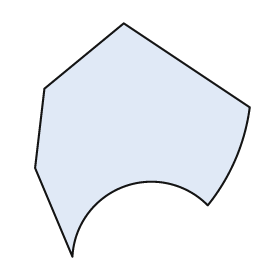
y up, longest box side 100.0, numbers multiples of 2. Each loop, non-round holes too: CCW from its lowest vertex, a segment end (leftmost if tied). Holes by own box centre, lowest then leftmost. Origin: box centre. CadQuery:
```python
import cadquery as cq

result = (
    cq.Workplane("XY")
    .moveTo(-30.0, -50.0)
    .threePointArc((-8.0, -20.0), (28.0, -28.0))
    .threePointArc((40.0, -8.0), (46.0, 14.0))
    .lineTo(-8.0, 50.0)
    .lineTo(-42.0, 22.0)
    .lineTo(-46.0, -12.0)
    .close()
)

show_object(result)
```